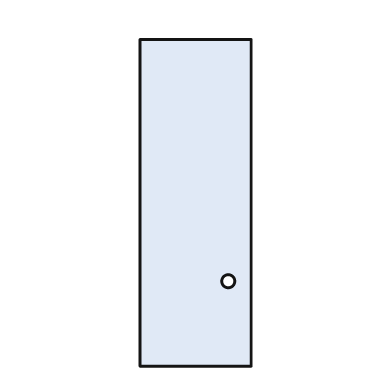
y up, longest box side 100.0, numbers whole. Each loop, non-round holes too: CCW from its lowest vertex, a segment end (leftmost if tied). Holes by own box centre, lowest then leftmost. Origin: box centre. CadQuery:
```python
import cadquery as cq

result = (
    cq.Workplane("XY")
    .moveTo(-17.0, -50.0)
    .lineTo(17.0, -50.0)
    .lineTo(17.0, 50.0)
    .lineTo(-17.0, 50.0)
    .close()
    .moveTo(10.0, -24.0)
    .circle(2.0)
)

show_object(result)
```